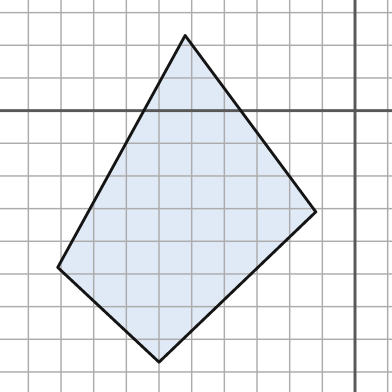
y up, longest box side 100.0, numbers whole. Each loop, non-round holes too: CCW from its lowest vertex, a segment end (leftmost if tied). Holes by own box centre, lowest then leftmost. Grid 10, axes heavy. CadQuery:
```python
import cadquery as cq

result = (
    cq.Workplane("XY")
    .moveTo(-60.0, -77.0)
    .lineTo(-12.0, -31.0)
    .lineTo(-52.0, 23.0)
    .lineTo(-91.0, -48.0)
    .close()
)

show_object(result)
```